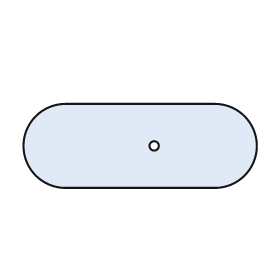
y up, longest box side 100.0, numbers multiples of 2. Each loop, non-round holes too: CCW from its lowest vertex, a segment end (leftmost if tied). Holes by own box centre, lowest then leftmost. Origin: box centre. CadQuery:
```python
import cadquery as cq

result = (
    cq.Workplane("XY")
    .moveTo(-32.0, -18.0)
    .lineTo(32.0, -18.0)
    .threePointArc((50.0, 0.0), (32.0, 18.0))
    .lineTo(-32.0, 18.0)
    .threePointArc((-50.0, 0.0), (-32.0, -18.0))
    .close()
    .moveTo(6.0, 0.0)
    .circle(2.0)
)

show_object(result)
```